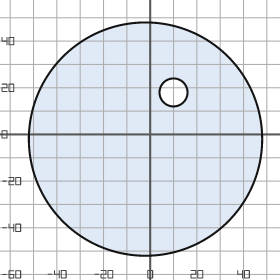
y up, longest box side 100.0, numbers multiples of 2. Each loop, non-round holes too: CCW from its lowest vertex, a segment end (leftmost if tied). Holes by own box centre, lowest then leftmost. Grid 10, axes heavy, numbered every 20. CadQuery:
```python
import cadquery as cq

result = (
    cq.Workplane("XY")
    .moveTo(-2.0, -2.0)
    .circle(50.0)
    .moveTo(10.0, 18.0)
    .circle(6.0)
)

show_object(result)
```